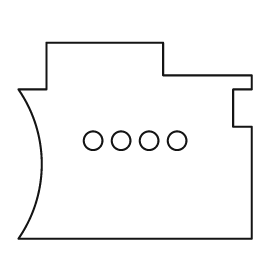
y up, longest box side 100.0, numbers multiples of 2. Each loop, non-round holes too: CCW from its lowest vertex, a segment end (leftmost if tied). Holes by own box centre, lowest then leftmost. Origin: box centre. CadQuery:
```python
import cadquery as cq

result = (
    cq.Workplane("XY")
    .moveTo(-50.0, -42.0)
    .lineTo(50.0, -42.0)
    .lineTo(50.0, 6.0)
    .lineTo(42.0, 6.0)
    .lineTo(42.0, 22.0)
    .lineTo(50.0, 22.0)
    .lineTo(50.0, 28.0)
    .lineTo(12.0, 28.0)
    .lineTo(12.0, 42.0)
    .lineTo(-38.0, 42.0)
    .lineTo(-38.0, 22.0)
    .lineTo(-50.0, 22.0)
    .threePointArc((-40.0, -10.0), (-50.0, -42.0))
    .close()
    .moveTo(-18.0, 0.0)
    .circle(4.0)
    .moveTo(-6.0, 0.0)
    .circle(4.0)
    .moveTo(6.0, 0.0)
    .circle(4.0)
    .moveTo(18.0, 0.0)
    .circle(4.0)
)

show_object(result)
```